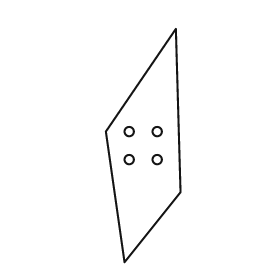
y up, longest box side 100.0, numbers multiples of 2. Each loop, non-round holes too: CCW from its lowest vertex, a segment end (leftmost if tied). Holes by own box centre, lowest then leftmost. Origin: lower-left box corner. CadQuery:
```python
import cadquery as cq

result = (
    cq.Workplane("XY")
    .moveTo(8.0, 0.0)
    .lineTo(32.0, 30.0)
    .lineTo(30.0, 100.0)
    .lineTo(0.0, 56.0)
    .close()
    .moveTo(10.0, 44.0)
    .circle(2.0)
    .moveTo(22.0, 44.0)
    .circle(2.0)
    .moveTo(10.0, 56.0)
    .circle(2.0)
    .moveTo(22.0, 56.0)
    .circle(2.0)
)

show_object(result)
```